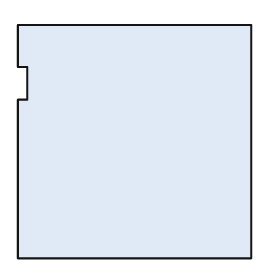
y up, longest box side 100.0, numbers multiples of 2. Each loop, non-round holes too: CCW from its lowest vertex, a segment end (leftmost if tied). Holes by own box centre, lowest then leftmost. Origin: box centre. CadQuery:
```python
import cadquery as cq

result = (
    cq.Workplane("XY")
    .moveTo(-50.0, -50.0)
    .lineTo(50.0, -50.0)
    .lineTo(50.0, 50.0)
    .lineTo(-50.0, 50.0)
    .lineTo(-50.0, 32.0)
    .lineTo(-46.0, 32.0)
    .lineTo(-46.0, 18.0)
    .lineTo(-50.0, 18.0)
    .close()
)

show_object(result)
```